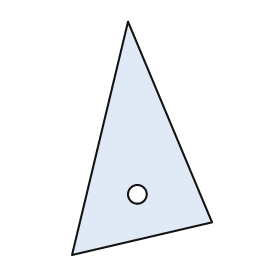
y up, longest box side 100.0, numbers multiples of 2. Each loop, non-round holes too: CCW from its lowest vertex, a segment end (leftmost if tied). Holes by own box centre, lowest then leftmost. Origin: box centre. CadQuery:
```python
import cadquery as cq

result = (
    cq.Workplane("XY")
    .moveTo(-30.0, -50.0)
    .lineTo(30.0, -36.0)
    .lineTo(-6.0, 50.0)
    .close()
    .moveTo(-2.0, -24.0)
    .circle(4.0)
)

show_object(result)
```